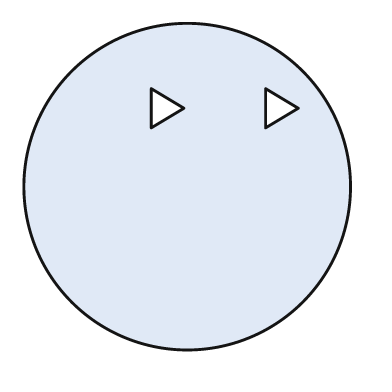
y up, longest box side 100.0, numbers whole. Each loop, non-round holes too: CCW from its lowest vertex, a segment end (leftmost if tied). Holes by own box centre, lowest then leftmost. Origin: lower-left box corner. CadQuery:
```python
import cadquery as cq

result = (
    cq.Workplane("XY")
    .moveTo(50.0, 50.0)
    .circle(50.0)
    .moveTo(39.0, 68.0)
    .lineTo(49.0, 74.0)
    .lineTo(39.0, 80.0)
    .close()
    .moveTo(74.0, 68.0)
    .lineTo(84.0, 74.0)
    .lineTo(74.0, 80.0)
    .close()
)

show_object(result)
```